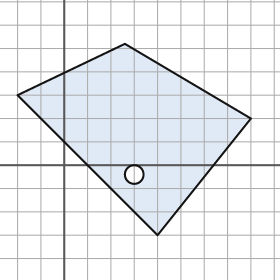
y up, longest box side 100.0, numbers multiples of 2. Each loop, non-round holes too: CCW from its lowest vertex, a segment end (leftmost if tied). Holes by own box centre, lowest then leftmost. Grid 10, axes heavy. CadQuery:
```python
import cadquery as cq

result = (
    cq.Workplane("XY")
    .moveTo(40.0, -30.0)
    .lineTo(80.0, 20.0)
    .lineTo(26.0, 52.0)
    .lineTo(-20.0, 30.0)
    .close()
    .moveTo(30.0, -4.0)
    .circle(4.0)
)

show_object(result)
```